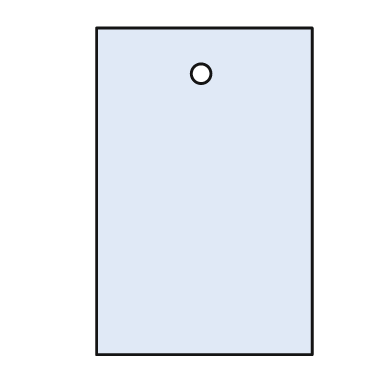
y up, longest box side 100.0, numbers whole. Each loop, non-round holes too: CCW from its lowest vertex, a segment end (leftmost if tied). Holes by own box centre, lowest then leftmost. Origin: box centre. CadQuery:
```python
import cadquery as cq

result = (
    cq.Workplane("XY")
    .moveTo(-33.0, -50.0)
    .lineTo(33.0, -50.0)
    .lineTo(33.0, 50.0)
    .lineTo(-33.0, 50.0)
    .close()
    .moveTo(-1.0, 36.0)
    .circle(3.0)
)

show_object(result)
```